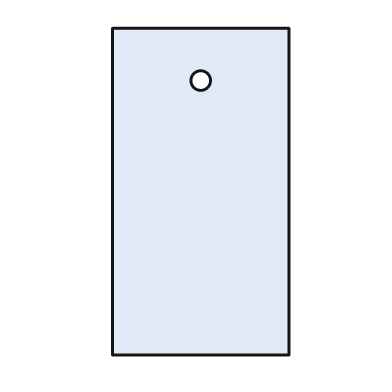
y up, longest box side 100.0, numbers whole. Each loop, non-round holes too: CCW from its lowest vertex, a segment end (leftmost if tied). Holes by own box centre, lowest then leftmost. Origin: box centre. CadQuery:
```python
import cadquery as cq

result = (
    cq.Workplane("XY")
    .moveTo(-27.0, -50.0)
    .lineTo(27.0, -50.0)
    .lineTo(27.0, 50.0)
    .lineTo(-27.0, 50.0)
    .close()
    .moveTo(0.0, 34.0)
    .circle(3.0)
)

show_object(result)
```